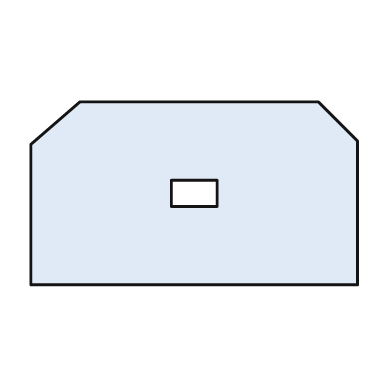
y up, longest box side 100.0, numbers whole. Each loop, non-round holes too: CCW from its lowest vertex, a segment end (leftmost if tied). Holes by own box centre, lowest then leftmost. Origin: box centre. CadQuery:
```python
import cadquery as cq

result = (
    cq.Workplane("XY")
    .moveTo(-50.0, -28.0)
    .lineTo(50.0, -28.0)
    .lineTo(50.0, 16.0)
    .lineTo(38.0, 28.0)
    .lineTo(-35.0, 28.0)
    .lineTo(-50.0, 15.0)
    .close()
    .moveTo(-7.0, -4.0)
    .lineTo(7.0, -4.0)
    .lineTo(7.0, 4.0)
    .lineTo(-7.0, 4.0)
    .close()
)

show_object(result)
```